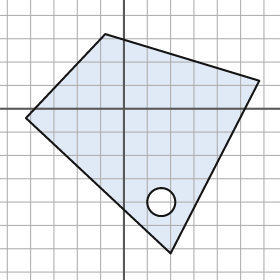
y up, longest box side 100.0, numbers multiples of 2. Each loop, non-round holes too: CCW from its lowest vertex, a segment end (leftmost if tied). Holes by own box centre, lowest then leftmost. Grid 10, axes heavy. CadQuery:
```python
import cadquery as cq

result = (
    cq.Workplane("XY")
    .moveTo(20.0, -62.0)
    .lineTo(58.0, 12.0)
    .lineTo(-8.0, 32.0)
    .lineTo(-42.0, -4.0)
    .close()
    .moveTo(16.0, -40.0)
    .circle(6.0)
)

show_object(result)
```